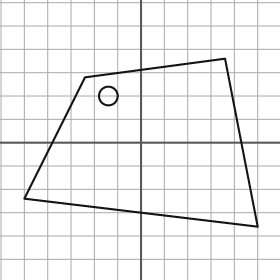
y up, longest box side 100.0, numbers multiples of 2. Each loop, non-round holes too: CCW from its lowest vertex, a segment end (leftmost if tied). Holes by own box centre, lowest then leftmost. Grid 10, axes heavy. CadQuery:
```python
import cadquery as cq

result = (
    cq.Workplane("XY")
    .moveTo(50.0, -36.0)
    .lineTo(36.0, 36.0)
    .lineTo(-24.0, 28.0)
    .lineTo(-50.0, -24.0)
    .close()
    .moveTo(-14.0, 20.0)
    .circle(4.0)
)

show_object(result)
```